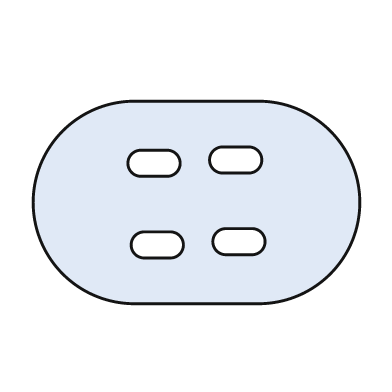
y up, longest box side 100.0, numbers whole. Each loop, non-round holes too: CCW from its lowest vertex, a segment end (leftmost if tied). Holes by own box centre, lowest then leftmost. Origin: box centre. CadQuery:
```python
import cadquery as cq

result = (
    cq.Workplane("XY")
    .moveTo(-19.0, -31.0)
    .lineTo(19.0, -31.0)
    .threePointArc((50.0, 0.0), (19.0, 31.0))
    .lineTo(-19.0, 31.0)
    .threePointArc((-50.0, 0.0), (-19.0, -31.0))
    .close()
    .moveTo(-16.0, -17.0)
    .lineTo(-8.0, -17.0)
    .threePointArc((-4.0, -13.0), (-8.0, -9.0))
    .lineTo(-16.0, -9.0)
    .threePointArc((-20.0, -13.0), (-16.0, -17.0))
    .close()
    .moveTo(9.0, -16.0)
    .lineTo(17.0, -16.0)
    .threePointArc((21.0, -12.0), (17.0, -8.0))
    .lineTo(9.0, -8.0)
    .threePointArc((5.0, -12.0), (9.0, -16.0))
    .close()
    .moveTo(-17.0, 8.0)
    .lineTo(-9.0, 8.0)
    .threePointArc((-5.0, 12.0), (-9.0, 16.0))
    .lineTo(-17.0, 16.0)
    .threePointArc((-21.0, 12.0), (-17.0, 8.0))
    .close()
    .moveTo(8.0, 9.0)
    .lineTo(16.0, 9.0)
    .threePointArc((20.0, 13.0), (16.0, 17.0))
    .lineTo(8.0, 17.0)
    .threePointArc((4.0, 13.0), (8.0, 9.0))
    .close()
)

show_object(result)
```